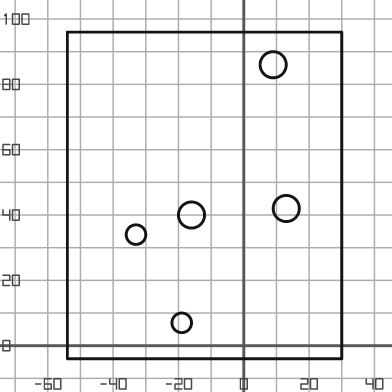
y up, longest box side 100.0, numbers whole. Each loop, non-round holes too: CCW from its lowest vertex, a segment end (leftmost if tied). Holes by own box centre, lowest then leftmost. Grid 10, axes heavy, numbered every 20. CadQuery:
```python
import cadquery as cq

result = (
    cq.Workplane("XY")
    .moveTo(-54.0, -4.0)
    .lineTo(30.0, -4.0)
    .lineTo(30.0, 96.0)
    .lineTo(-54.0, 96.0)
    .close()
    .moveTo(-19.0, 7.0)
    .circle(3.0)
    .moveTo(-33.0, 34.0)
    .circle(3.0)
    .moveTo(-16.0, 40.0)
    .circle(4.0)
    .moveTo(13.0, 42.0)
    .circle(4.0)
    .moveTo(9.0, 86.0)
    .circle(4.0)
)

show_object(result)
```